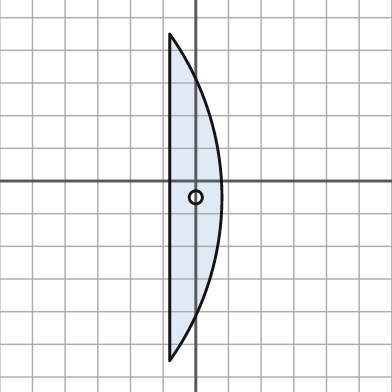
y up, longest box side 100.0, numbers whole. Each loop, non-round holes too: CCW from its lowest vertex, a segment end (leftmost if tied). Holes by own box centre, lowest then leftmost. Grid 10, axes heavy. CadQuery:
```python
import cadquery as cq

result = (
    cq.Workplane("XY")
    .moveTo(-8.0, -55.0)
    .threePointArc((8.0, -5.0), (-8.0, 45.0))
    .close()
    .moveTo(0.0, -5.0)
    .circle(2.0)
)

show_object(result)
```